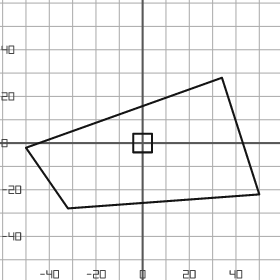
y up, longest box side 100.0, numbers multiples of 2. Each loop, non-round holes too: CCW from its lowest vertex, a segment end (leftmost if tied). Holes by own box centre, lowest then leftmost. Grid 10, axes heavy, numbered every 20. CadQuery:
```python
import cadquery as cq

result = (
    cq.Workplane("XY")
    .moveTo(-32.0, -28.0)
    .lineTo(50.0, -22.0)
    .lineTo(34.0, 28.0)
    .lineTo(-50.0, -2.0)
    .close()
    .moveTo(-4.0, -4.0)
    .lineTo(4.0, -4.0)
    .lineTo(4.0, 4.0)
    .lineTo(-4.0, 4.0)
    .close()
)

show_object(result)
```